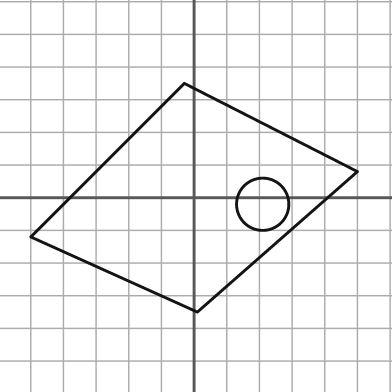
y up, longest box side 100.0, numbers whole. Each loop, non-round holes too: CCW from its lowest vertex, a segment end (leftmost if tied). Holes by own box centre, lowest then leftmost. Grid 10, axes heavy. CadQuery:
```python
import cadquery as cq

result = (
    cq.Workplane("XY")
    .moveTo(1.0, -35.0)
    .lineTo(50.0, 8.0)
    .lineTo(-3.0, 35.0)
    .lineTo(-50.0, -12.0)
    .close()
    .moveTo(21.0, -2.0)
    .circle(8.0)
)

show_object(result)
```